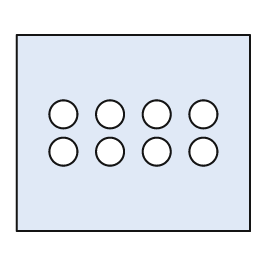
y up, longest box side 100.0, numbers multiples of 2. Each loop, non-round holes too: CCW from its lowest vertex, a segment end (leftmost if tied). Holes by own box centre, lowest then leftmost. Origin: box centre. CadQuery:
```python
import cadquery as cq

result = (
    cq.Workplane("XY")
    .moveTo(-50.0, -42.0)
    .lineTo(50.0, -42.0)
    .lineTo(50.0, 42.0)
    .lineTo(-50.0, 42.0)
    .close()
    .moveTo(-30.0, -8.0)
    .circle(6.0)
    .moveTo(-10.0, -8.0)
    .circle(6.0)
    .moveTo(10.0, -8.0)
    .circle(6.0)
    .moveTo(30.0, -8.0)
    .circle(6.0)
    .moveTo(-30.0, 8.0)
    .circle(6.0)
    .moveTo(-10.0, 8.0)
    .circle(6.0)
    .moveTo(10.0, 8.0)
    .circle(6.0)
    .moveTo(30.0, 8.0)
    .circle(6.0)
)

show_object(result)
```